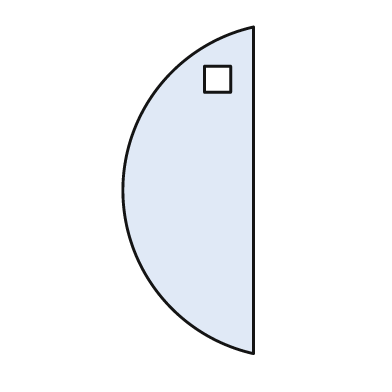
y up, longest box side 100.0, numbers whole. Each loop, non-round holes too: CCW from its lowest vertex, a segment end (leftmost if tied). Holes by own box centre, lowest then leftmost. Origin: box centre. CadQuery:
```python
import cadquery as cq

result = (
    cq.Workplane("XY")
    .moveTo(20.0, -50.0)
    .lineTo(20.0, 50.0)
    .threePointArc((-20.0, 0.0), (20.0, -50.0))
    .close()
    .moveTo(5.0, 30.0)
    .lineTo(13.0, 30.0)
    .lineTo(13.0, 38.0)
    .lineTo(5.0, 38.0)
    .close()
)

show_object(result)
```